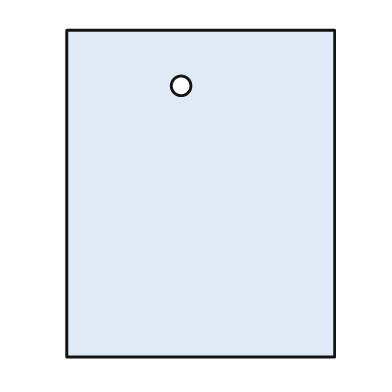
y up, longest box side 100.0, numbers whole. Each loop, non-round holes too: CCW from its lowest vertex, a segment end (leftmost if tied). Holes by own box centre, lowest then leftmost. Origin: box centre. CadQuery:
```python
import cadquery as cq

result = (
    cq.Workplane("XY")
    .moveTo(-41.0, -50.0)
    .lineTo(41.0, -50.0)
    .lineTo(41.0, 50.0)
    .lineTo(-41.0, 50.0)
    .close()
    .moveTo(-6.0, 33.0)
    .circle(3.0)
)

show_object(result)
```